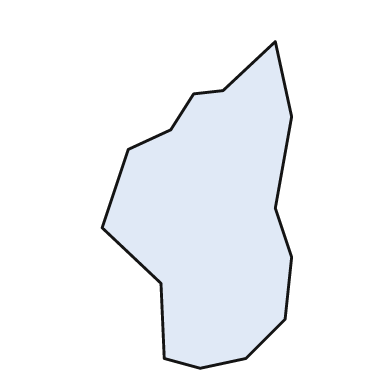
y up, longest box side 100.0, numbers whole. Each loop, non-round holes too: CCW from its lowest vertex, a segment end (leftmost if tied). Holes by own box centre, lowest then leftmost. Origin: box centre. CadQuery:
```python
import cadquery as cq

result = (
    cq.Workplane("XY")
    .moveTo(1.0, -50.0)
    .lineTo(15.0, -47.0)
    .lineTo(27.0, -35.0)
    .lineTo(29.0, -16.0)
    .lineTo(24.0, -1.0)
    .lineTo(29.0, 27.0)
    .lineTo(24.0, 50.0)
    .lineTo(8.0, 35.0)
    .lineTo(-1.0, 34.0)
    .lineTo(-8.0, 23.0)
    .lineTo(-21.0, 17.0)
    .lineTo(-29.0, -7.0)
    .lineTo(-11.0, -24.0)
    .lineTo(-10.0, -47.0)
    .close()
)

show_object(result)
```